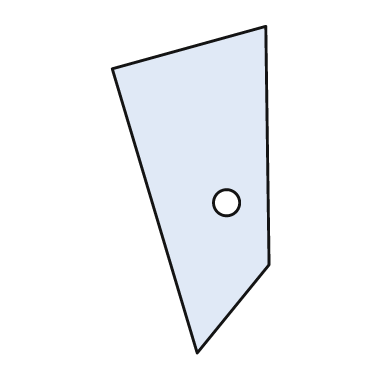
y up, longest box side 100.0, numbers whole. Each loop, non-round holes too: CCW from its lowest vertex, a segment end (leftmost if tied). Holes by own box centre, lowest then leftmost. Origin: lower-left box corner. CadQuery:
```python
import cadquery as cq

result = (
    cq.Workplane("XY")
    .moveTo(26.0, 0.0)
    .lineTo(48.0, 27.0)
    .lineTo(47.0, 100.0)
    .lineTo(0.0, 87.0)
    .close()
    .moveTo(35.0, 46.0)
    .circle(4.0)
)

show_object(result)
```